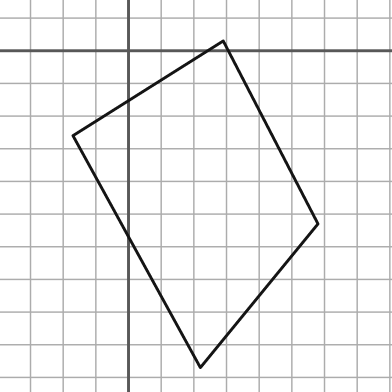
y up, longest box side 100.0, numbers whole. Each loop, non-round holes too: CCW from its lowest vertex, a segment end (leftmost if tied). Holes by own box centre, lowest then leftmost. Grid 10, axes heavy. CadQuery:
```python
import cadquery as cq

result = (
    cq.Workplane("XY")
    .moveTo(22.0, -97.0)
    .lineTo(58.0, -53.0)
    .lineTo(29.0, 3.0)
    .lineTo(-17.0, -26.0)
    .close()
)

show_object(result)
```